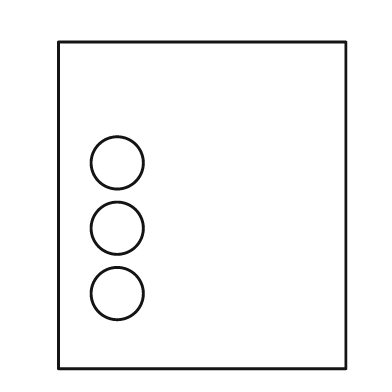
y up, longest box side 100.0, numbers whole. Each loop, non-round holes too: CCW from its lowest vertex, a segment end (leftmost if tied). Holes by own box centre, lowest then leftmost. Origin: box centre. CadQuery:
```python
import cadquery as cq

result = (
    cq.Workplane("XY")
    .moveTo(-44.0, -50.0)
    .lineTo(44.0, -50.0)
    .lineTo(44.0, 50.0)
    .lineTo(-44.0, 50.0)
    .close()
    .moveTo(-26.0, -27.0)
    .circle(8.0)
    .moveTo(-26.0, -7.0)
    .circle(8.0)
    .moveTo(-26.0, 13.0)
    .circle(8.0)
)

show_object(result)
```